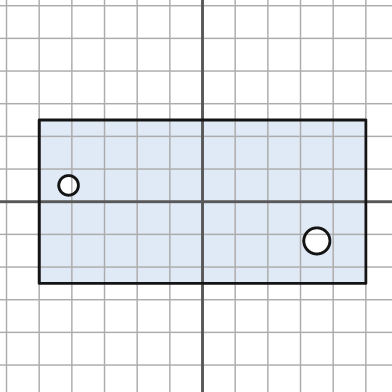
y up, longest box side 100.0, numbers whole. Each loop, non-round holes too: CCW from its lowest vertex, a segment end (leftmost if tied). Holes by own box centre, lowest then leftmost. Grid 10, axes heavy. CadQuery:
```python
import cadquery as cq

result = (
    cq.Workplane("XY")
    .moveTo(-50.0, -25.0)
    .lineTo(50.0, -25.0)
    .lineTo(50.0, 25.0)
    .lineTo(-50.0, 25.0)
    .close()
    .moveTo(35.0, -12.0)
    .circle(4.0)
    .moveTo(-41.0, 5.0)
    .circle(3.0)
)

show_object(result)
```